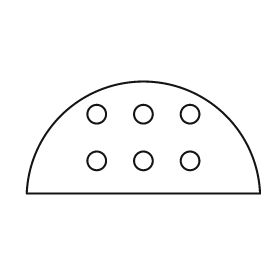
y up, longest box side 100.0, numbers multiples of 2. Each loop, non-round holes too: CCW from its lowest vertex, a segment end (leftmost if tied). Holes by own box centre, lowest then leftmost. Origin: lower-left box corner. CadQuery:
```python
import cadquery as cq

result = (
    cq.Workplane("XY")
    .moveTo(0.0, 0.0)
    .lineTo(100.0, 0.0)
    .threePointArc((50.0, 48.0), (0.0, 0.0))
    .close()
    .moveTo(30.0, 14.0)
    .circle(4.0)
    .moveTo(50.0, 14.0)
    .circle(4.0)
    .moveTo(70.0, 14.0)
    .circle(4.0)
    .moveTo(30.0, 34.0)
    .circle(4.0)
    .moveTo(50.0, 34.0)
    .circle(4.0)
    .moveTo(70.0, 34.0)
    .circle(4.0)
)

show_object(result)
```